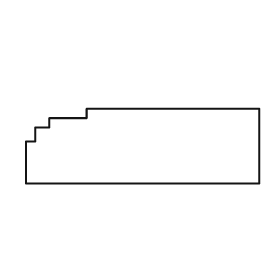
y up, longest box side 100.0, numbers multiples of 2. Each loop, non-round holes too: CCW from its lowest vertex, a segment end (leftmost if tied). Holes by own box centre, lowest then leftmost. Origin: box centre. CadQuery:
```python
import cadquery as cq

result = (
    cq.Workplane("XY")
    .moveTo(-50.0, -16.0)
    .lineTo(50.0, -16.0)
    .lineTo(50.0, 16.0)
    .lineTo(-24.0, 16.0)
    .lineTo(-24.0, 12.0)
    .lineTo(-40.0, 12.0)
    .lineTo(-40.0, 8.0)
    .lineTo(-46.0, 8.0)
    .lineTo(-46.0, 2.0)
    .lineTo(-50.0, 2.0)
    .close()
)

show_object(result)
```